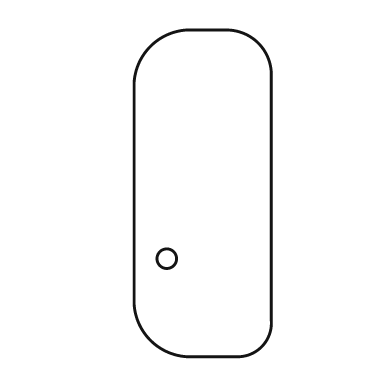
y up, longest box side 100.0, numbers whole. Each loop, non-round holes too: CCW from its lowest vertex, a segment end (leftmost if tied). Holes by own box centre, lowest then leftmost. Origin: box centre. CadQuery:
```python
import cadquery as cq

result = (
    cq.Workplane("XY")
    .moveTo(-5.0, -50.0)
    .lineTo(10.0, -50.0)
    .threePointArc((18.0, -47.0), (21.0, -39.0))
    .lineTo(21.0, 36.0)
    .threePointArc((17.0, 46.0), (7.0, 50.0))
    .lineTo(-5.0, 50.0)
    .threePointArc((-16.0, 45.0), (-21.0, 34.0))
    .lineTo(-21.0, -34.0)
    .threePointArc((-16.0, -45.0), (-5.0, -50.0))
    .close()
    .moveTo(-11.0, -20.0)
    .circle(3.0)
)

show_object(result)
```